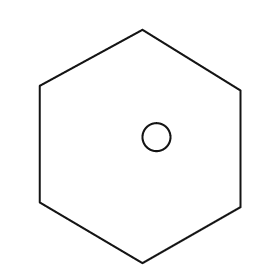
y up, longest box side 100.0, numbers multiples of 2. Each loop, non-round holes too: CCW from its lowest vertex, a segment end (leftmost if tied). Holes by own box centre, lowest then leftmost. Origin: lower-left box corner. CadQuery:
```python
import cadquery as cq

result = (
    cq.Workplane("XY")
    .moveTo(44.0, 0.0)
    .lineTo(86.0, 24.0)
    .lineTo(86.0, 74.0)
    .lineTo(44.0, 100.0)
    .lineTo(0.0, 76.0)
    .lineTo(0.0, 26.0)
    .close()
    .moveTo(50.0, 54.0)
    .circle(6.0)
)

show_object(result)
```